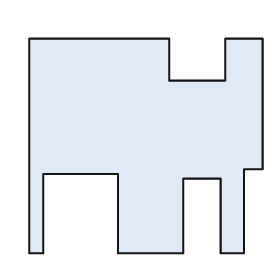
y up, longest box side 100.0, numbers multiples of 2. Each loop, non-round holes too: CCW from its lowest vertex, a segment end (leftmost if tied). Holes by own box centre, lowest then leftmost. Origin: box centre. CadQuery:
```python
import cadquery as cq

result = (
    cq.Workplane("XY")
    .moveTo(-50.0, -46.0)
    .lineTo(-44.0, -46.0)
    .lineTo(-44.0, -12.0)
    .lineTo(-12.0, -12.0)
    .lineTo(-12.0, -46.0)
    .lineTo(16.0, -46.0)
    .lineTo(16.0, -14.0)
    .lineTo(32.0, -14.0)
    .lineTo(32.0, -46.0)
    .lineTo(42.0, -46.0)
    .lineTo(42.0, -10.0)
    .lineTo(50.0, -10.0)
    .lineTo(50.0, 46.0)
    .lineTo(34.0, 46.0)
    .lineTo(34.0, 28.0)
    .lineTo(10.0, 28.0)
    .lineTo(10.0, 46.0)
    .lineTo(-50.0, 46.0)
    .close()
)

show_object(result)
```